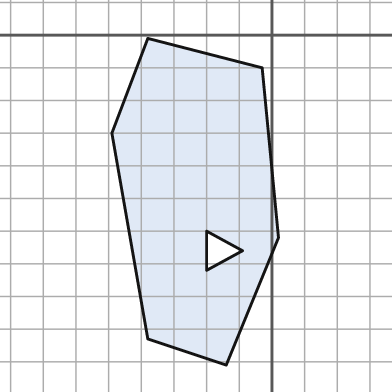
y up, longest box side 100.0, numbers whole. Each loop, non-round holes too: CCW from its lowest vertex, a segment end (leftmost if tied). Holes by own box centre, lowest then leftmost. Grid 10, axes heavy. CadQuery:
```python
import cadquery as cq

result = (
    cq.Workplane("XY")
    .moveTo(-14.0, -101.0)
    .lineTo(2.0, -62.0)
    .lineTo(-3.0, -10.0)
    .lineTo(-38.0, -1.0)
    .lineTo(-49.0, -30.0)
    .lineTo(-38.0, -93.0)
    .close()
    .moveTo(-20.0, -72.0)
    .lineTo(-9.0, -66.0)
    .lineTo(-20.0, -60.0)
    .close()
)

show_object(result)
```